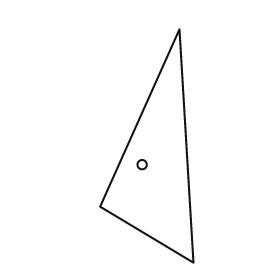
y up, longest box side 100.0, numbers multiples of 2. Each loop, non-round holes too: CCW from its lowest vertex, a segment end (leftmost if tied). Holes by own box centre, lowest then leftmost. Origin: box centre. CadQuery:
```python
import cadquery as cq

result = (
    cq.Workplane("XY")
    .moveTo(20.0, -50.0)
    .lineTo(14.0, 50.0)
    .lineTo(-20.0, -26.0)
    .close()
    .moveTo(-2.0, -8.0)
    .circle(2.0)
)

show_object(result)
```